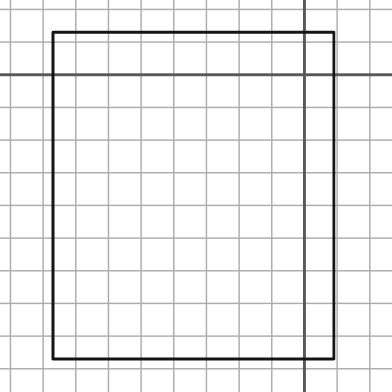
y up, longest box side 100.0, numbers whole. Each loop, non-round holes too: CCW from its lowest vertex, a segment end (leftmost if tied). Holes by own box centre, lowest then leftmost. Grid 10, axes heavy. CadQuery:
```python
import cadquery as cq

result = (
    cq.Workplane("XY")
    .moveTo(-77.0, -87.0)
    .lineTo(9.0, -87.0)
    .lineTo(9.0, 13.0)
    .lineTo(-77.0, 13.0)
    .close()
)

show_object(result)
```